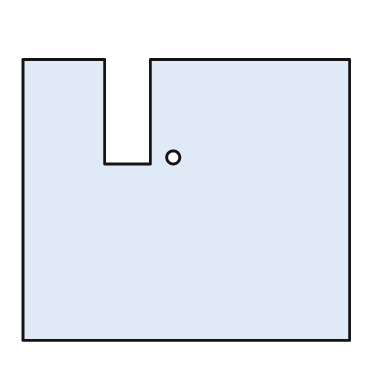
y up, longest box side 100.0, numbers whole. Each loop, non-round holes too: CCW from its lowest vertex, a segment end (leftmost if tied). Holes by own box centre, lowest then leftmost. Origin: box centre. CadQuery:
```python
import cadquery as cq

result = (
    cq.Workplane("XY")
    .moveTo(-50.0, -43.0)
    .lineTo(50.0, -43.0)
    .lineTo(50.0, 43.0)
    .lineTo(-11.0, 43.0)
    .lineTo(-11.0, 11.0)
    .lineTo(-25.0, 11.0)
    .lineTo(-25.0, 43.0)
    .lineTo(-50.0, 43.0)
    .close()
    .moveTo(-4.0, 13.0)
    .circle(2.0)
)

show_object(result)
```